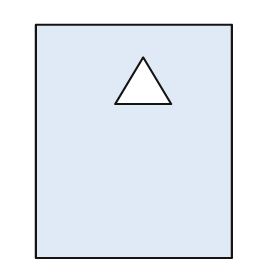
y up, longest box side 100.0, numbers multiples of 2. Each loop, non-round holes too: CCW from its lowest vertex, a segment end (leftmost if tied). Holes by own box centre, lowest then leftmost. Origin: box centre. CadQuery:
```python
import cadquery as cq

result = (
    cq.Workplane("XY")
    .moveTo(-42.0, -50.0)
    .lineTo(42.0, -50.0)
    .lineTo(42.0, 50.0)
    .lineTo(-42.0, 50.0)
    .close()
    .moveTo(-8.0, 16.0)
    .lineTo(16.0, 16.0)
    .lineTo(4.0, 36.0)
    .close()
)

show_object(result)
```